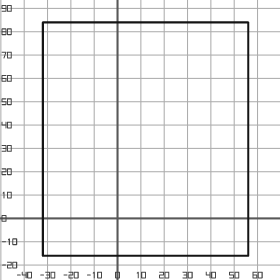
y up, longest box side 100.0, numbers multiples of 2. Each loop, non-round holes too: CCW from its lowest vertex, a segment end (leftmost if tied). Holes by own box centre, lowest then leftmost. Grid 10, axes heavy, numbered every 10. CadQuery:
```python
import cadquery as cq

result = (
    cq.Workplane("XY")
    .moveTo(-32.0, -16.0)
    .lineTo(56.0, -16.0)
    .lineTo(56.0, 84.0)
    .lineTo(-32.0, 84.0)
    .close()
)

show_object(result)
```